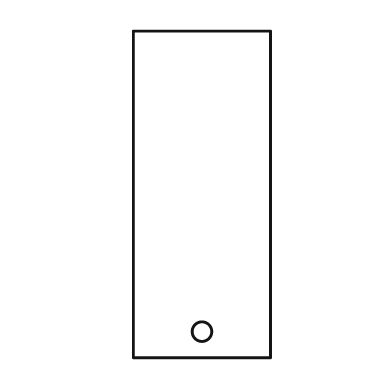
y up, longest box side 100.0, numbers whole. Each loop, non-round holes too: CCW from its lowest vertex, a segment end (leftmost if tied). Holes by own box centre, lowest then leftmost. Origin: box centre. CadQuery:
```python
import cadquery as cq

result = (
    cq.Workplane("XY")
    .moveTo(-21.0, -50.0)
    .lineTo(21.0, -50.0)
    .lineTo(21.0, 50.0)
    .lineTo(-21.0, 50.0)
    .close()
    .moveTo(0.0, -42.0)
    .circle(3.0)
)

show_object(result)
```